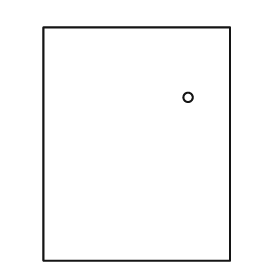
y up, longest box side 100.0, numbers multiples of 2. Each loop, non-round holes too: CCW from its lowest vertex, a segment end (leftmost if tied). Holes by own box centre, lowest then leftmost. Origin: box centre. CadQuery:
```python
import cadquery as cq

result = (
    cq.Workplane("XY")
    .moveTo(-40.0, -50.0)
    .lineTo(40.0, -50.0)
    .lineTo(40.0, 50.0)
    .lineTo(-40.0, 50.0)
    .close()
    .moveTo(22.0, 20.0)
    .circle(2.0)
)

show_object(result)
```